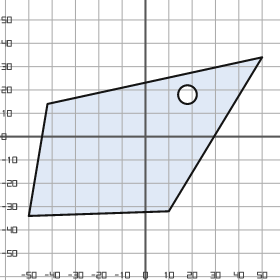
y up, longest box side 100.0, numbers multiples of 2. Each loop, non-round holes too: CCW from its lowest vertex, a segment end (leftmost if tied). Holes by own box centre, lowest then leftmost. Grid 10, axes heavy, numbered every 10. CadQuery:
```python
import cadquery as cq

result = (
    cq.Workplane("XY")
    .moveTo(-50.0, -34.0)
    .lineTo(10.0, -32.0)
    .lineTo(50.0, 34.0)
    .lineTo(-42.0, 14.0)
    .close()
    .moveTo(18.0, 18.0)
    .circle(4.0)
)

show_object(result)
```